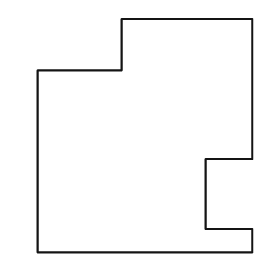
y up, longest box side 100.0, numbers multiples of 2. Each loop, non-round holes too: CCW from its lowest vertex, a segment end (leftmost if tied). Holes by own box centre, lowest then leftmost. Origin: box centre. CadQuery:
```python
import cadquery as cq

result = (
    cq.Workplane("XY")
    .moveTo(-46.0, -50.0)
    .lineTo(46.0, -50.0)
    .lineTo(46.0, -40.0)
    .lineTo(26.0, -40.0)
    .lineTo(26.0, -10.0)
    .lineTo(46.0, -10.0)
    .lineTo(46.0, 50.0)
    .lineTo(-10.0, 50.0)
    .lineTo(-10.0, 28.0)
    .lineTo(-46.0, 28.0)
    .close()
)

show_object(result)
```